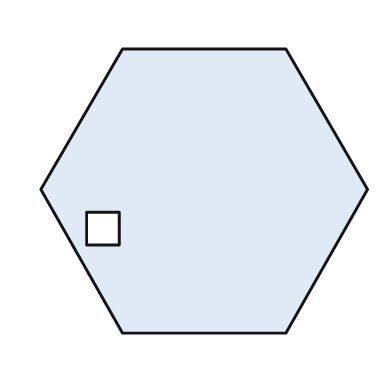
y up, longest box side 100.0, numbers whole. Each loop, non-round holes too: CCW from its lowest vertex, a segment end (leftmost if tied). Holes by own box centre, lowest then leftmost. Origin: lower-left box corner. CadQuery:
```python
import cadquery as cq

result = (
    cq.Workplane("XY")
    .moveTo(25.0, 0.0)
    .lineTo(75.0, 0.0)
    .lineTo(100.0, 44.0)
    .lineTo(75.0, 87.0)
    .lineTo(25.0, 87.0)
    .lineTo(0.0, 44.0)
    .close()
    .moveTo(14.0, 27.0)
    .lineTo(24.0, 27.0)
    .lineTo(24.0, 37.0)
    .lineTo(14.0, 37.0)
    .close()
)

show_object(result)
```